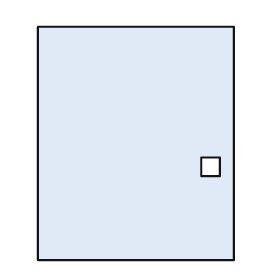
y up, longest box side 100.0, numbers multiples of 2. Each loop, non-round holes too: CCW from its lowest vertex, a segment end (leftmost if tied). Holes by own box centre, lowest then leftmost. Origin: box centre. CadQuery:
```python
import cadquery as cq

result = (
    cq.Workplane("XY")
    .moveTo(-42.0, -50.0)
    .lineTo(42.0, -50.0)
    .lineTo(42.0, 50.0)
    .lineTo(-42.0, 50.0)
    .close()
    .moveTo(28.0, -14.0)
    .lineTo(36.0, -14.0)
    .lineTo(36.0, -6.0)
    .lineTo(28.0, -6.0)
    .close()
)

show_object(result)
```